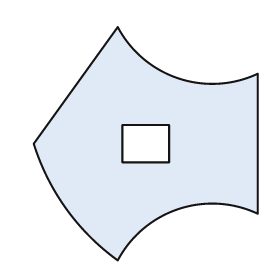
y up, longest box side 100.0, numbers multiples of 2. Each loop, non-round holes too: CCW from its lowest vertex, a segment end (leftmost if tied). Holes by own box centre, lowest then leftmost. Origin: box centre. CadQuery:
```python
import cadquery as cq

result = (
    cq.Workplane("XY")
    .moveTo(-12.0, -50.0)
    .threePointArc((14.0, -28.0), (48.0, -30.0))
    .lineTo(48.0, 30.0)
    .threePointArc((14.0, 28.0), (-12.0, 50.0))
    .lineTo(-48.0, 0.0)
    .threePointArc((-34.0, -28.0), (-12.0, -50.0))
    .close()
    .moveTo(-10.0, -8.0)
    .lineTo(10.0, -8.0)
    .lineTo(10.0, 8.0)
    .lineTo(-10.0, 8.0)
    .close()
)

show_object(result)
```